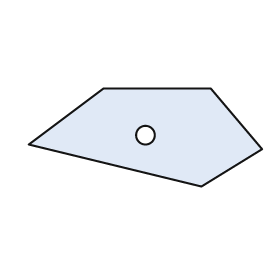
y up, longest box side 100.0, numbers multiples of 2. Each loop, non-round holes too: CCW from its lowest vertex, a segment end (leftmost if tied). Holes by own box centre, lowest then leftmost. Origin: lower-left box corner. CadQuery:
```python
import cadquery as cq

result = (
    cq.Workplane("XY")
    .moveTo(74.0, 0.0)
    .lineTo(100.0, 16.0)
    .lineTo(78.0, 42.0)
    .lineTo(32.0, 42.0)
    .lineTo(0.0, 18.0)
    .close()
    .moveTo(50.0, 22.0)
    .circle(4.0)
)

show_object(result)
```